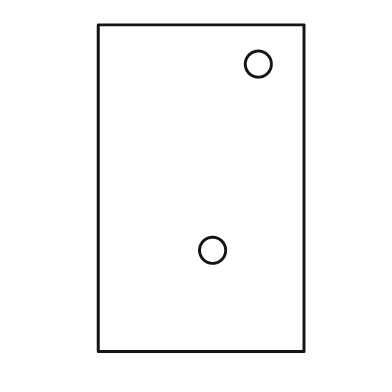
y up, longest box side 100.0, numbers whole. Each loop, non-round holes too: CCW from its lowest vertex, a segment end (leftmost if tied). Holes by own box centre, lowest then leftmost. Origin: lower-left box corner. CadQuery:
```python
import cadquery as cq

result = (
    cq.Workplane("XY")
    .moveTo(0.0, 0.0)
    .lineTo(63.0, 0.0)
    .lineTo(63.0, 100.0)
    .lineTo(0.0, 100.0)
    .close()
    .moveTo(35.0, 31.0)
    .circle(4.0)
    .moveTo(49.0, 88.0)
    .circle(4.0)
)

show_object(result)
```